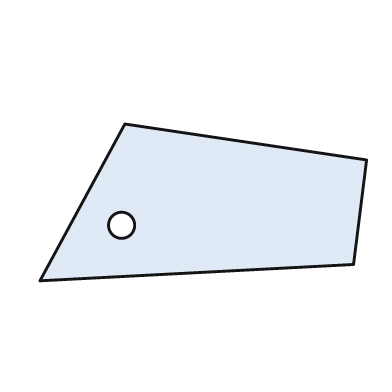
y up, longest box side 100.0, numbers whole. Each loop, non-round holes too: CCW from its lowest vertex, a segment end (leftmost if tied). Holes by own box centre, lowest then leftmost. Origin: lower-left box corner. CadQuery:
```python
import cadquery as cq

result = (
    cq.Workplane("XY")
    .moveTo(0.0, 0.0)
    .lineTo(96.0, 5.0)
    .lineTo(100.0, 37.0)
    .lineTo(26.0, 48.0)
    .close()
    .moveTo(25.0, 17.0)
    .circle(4.0)
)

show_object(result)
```